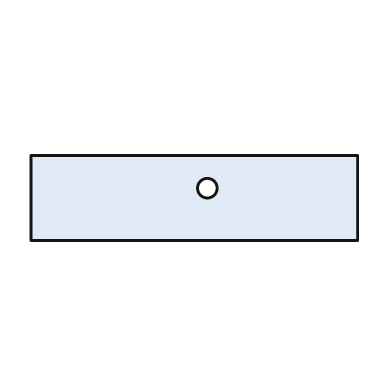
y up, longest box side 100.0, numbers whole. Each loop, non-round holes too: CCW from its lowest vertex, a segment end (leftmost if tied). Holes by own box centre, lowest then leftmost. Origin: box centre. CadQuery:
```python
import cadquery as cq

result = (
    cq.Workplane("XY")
    .moveTo(-50.0, -13.0)
    .lineTo(50.0, -13.0)
    .lineTo(50.0, 13.0)
    .lineTo(-50.0, 13.0)
    .close()
    .moveTo(4.0, 3.0)
    .circle(3.0)
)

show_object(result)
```